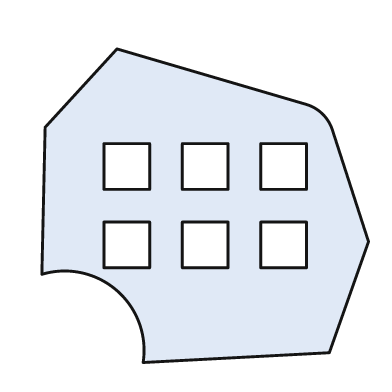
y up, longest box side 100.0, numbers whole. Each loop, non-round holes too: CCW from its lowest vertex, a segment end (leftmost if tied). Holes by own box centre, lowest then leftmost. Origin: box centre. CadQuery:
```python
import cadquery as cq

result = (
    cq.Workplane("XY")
    .moveTo(-19.0, -48.0)
    .lineTo(38.0, -45.0)
    .lineTo(50.0, -11.0)
    .lineTo(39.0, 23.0)
    .threePointArc((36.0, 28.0), (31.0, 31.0))
    .lineTo(-27.0, 48.0)
    .lineTo(-49.0, 24.0)
    .lineTo(-50.0, -21.0)
    .threePointArc((-27.0, -26.0), (-19.0, -48.0))
    .close()
    .moveTo(-31.0, -19.0)
    .lineTo(-17.0, -19.0)
    .lineTo(-17.0, -5.0)
    .lineTo(-31.0, -5.0)
    .close()
    .moveTo(-7.0, -19.0)
    .lineTo(7.0, -19.0)
    .lineTo(7.0, -5.0)
    .lineTo(-7.0, -5.0)
    .close()
    .moveTo(17.0, -19.0)
    .lineTo(31.0, -19.0)
    .lineTo(31.0, -5.0)
    .lineTo(17.0, -5.0)
    .close()
    .moveTo(-31.0, 5.0)
    .lineTo(-17.0, 5.0)
    .lineTo(-17.0, 19.0)
    .lineTo(-31.0, 19.0)
    .close()
    .moveTo(-7.0, 5.0)
    .lineTo(7.0, 5.0)
    .lineTo(7.0, 19.0)
    .lineTo(-7.0, 19.0)
    .close()
    .moveTo(17.0, 5.0)
    .lineTo(31.0, 5.0)
    .lineTo(31.0, 19.0)
    .lineTo(17.0, 19.0)
    .close()
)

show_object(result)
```